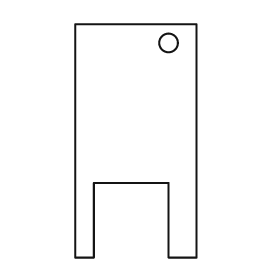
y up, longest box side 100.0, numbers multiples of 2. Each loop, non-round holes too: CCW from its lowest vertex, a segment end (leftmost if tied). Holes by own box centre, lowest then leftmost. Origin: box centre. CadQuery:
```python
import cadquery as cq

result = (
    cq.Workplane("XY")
    .moveTo(-26.0, -50.0)
    .lineTo(-18.0, -50.0)
    .lineTo(-18.0, -18.0)
    .lineTo(14.0, -18.0)
    .lineTo(14.0, -50.0)
    .lineTo(26.0, -50.0)
    .lineTo(26.0, 50.0)
    .lineTo(-26.0, 50.0)
    .close()
    .moveTo(14.0, 42.0)
    .circle(4.0)
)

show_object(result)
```